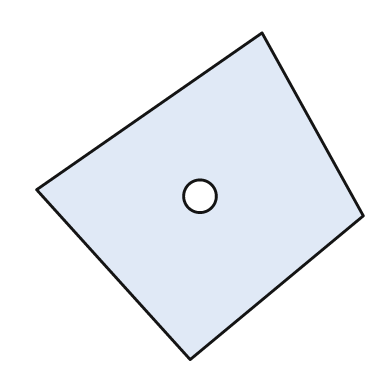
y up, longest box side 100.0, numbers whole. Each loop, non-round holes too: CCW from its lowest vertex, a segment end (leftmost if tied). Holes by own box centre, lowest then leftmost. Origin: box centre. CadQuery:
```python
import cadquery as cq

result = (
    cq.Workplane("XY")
    .moveTo(-3.0, -50.0)
    .lineTo(50.0, -6.0)
    .lineTo(19.0, 50.0)
    .lineTo(-50.0, 2.0)
    .close()
    .moveTo(0.0, 0.0)
    .circle(5.0)
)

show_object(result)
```